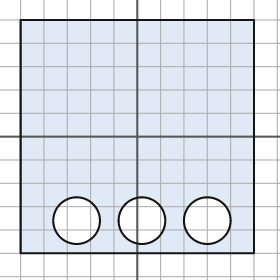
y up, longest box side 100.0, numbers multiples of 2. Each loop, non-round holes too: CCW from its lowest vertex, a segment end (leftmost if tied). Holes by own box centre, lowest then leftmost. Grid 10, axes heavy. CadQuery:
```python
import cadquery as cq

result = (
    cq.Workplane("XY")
    .moveTo(-50.0, -50.0)
    .lineTo(50.0, -50.0)
    .lineTo(50.0, 50.0)
    .lineTo(-50.0, 50.0)
    .close()
    .moveTo(-26.0, -36.0)
    .circle(10.0)
    .moveTo(2.0, -36.0)
    .circle(10.0)
    .moveTo(30.0, -36.0)
    .circle(10.0)
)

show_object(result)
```